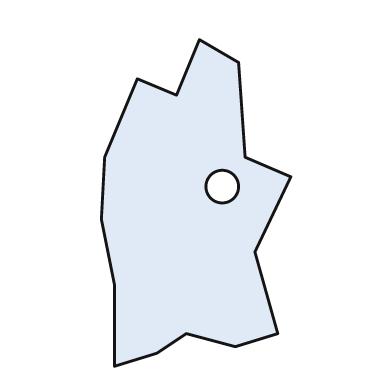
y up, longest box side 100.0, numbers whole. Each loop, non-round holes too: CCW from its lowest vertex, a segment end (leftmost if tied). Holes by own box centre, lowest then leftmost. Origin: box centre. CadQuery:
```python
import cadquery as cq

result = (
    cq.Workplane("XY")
    .moveTo(-25.0, -50.0)
    .lineTo(-12.0, -46.0)
    .lineTo(-3.0, -40.0)
    .lineTo(12.0, -44.0)
    .lineTo(25.0, -40.0)
    .lineTo(18.0, -15.0)
    .lineTo(29.0, 8.0)
    .lineTo(15.0, 14.0)
    .lineTo(13.0, 43.0)
    .lineTo(1.0, 50.0)
    .lineTo(-6.0, 33.0)
    .lineTo(-18.0, 38.0)
    .lineTo(-28.0, 14.0)
    .lineTo(-29.0, -5.0)
    .lineTo(-25.0, -25.0)
    .close()
    .moveTo(8.0, 5.0)
    .circle(5.0)
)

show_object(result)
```